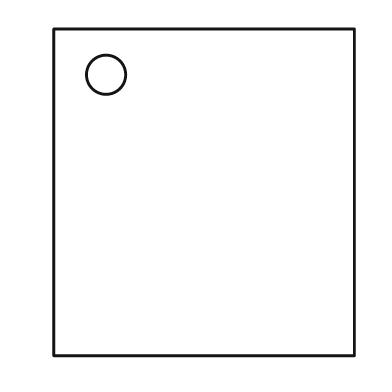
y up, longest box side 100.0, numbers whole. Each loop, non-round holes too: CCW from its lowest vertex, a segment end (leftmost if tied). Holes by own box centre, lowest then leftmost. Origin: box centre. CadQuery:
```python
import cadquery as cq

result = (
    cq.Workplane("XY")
    .moveTo(-46.0, -50.0)
    .lineTo(46.0, -50.0)
    .lineTo(46.0, 50.0)
    .lineTo(-46.0, 50.0)
    .close()
    .moveTo(-30.0, 36.0)
    .circle(6.0)
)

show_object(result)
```